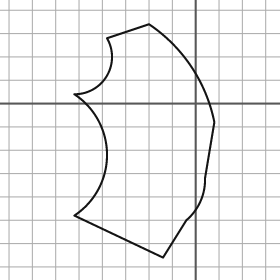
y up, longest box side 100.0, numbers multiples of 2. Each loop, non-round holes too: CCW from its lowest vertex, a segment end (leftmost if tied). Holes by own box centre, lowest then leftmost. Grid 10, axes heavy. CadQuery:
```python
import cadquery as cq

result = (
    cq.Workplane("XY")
    .moveTo(-14.0, -66.0)
    .lineTo(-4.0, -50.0)
    .threePointArc((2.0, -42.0), (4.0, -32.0))
    .lineTo(8.0, -8.0)
    .threePointArc((-2.0, 16.0), (-20.0, 34.0))
    .lineTo(-38.0, 28.0)
    .threePointArc((-38.0, 12.0), (-52.0, 4.0))
    .threePointArc((-38.0, -22.0), (-52.0, -48.0))
    .close()
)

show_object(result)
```